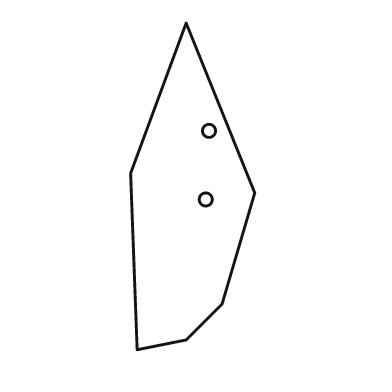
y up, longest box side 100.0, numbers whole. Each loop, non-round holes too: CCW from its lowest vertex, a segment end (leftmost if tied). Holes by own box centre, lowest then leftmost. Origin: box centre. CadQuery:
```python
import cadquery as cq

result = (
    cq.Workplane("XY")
    .moveTo(-17.0, -50.0)
    .lineTo(-2.0, -47.0)
    .lineTo(9.0, -36.0)
    .lineTo(19.0, -2.0)
    .lineTo(-2.0, 50.0)
    .lineTo(-19.0, 4.0)
    .close()
    .moveTo(4.0, -4.0)
    .circle(2.0)
    .moveTo(5.0, 17.0)
    .circle(2.0)
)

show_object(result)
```